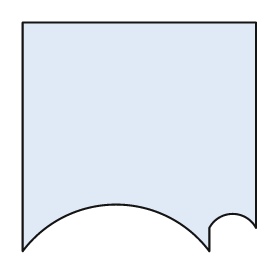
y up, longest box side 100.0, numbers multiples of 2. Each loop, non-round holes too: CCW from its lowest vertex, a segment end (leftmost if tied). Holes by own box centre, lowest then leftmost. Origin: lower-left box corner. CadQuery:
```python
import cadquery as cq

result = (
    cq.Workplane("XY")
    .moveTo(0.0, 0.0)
    .threePointArc((40.0, 20.0), (80.0, 0.0))
    .lineTo(80.0, 10.0)
    .threePointArc((90.0, 16.0), (100.0, 10.0))
    .lineTo(100.0, 98.0)
    .lineTo(0.0, 98.0)
    .close()
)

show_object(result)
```